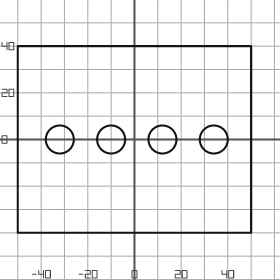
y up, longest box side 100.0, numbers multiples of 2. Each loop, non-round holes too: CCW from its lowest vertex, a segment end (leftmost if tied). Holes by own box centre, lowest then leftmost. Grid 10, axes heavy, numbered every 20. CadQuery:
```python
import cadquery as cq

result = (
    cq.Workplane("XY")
    .moveTo(-50.0, -40.0)
    .lineTo(50.0, -40.0)
    .lineTo(50.0, 40.0)
    .lineTo(-50.0, 40.0)
    .close()
    .moveTo(-32.0, 0.0)
    .circle(6.0)
    .moveTo(-10.0, 0.0)
    .circle(6.0)
    .moveTo(12.0, 0.0)
    .circle(6.0)
    .moveTo(34.0, 0.0)
    .circle(6.0)
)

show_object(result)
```